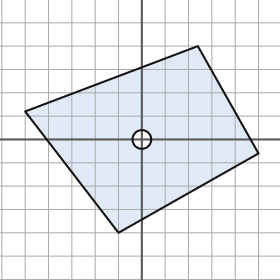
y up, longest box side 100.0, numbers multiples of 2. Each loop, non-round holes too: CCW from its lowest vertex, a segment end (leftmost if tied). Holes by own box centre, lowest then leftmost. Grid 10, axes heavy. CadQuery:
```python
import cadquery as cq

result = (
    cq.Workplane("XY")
    .moveTo(-10.0, -40.0)
    .lineTo(50.0, -6.0)
    .lineTo(24.0, 40.0)
    .lineTo(-50.0, 12.0)
    .close()
    .moveTo(0.0, 0.0)
    .circle(4.0)
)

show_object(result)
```